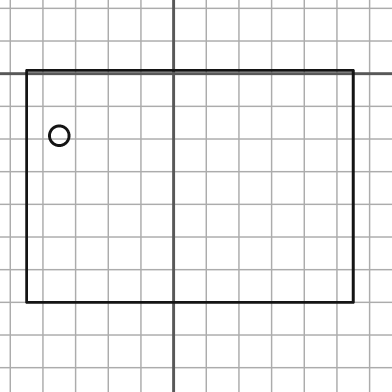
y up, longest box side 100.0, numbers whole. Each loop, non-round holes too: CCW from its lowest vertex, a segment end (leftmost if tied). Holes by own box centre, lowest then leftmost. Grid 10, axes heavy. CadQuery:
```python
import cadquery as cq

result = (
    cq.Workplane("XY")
    .moveTo(-45.0, -70.0)
    .lineTo(55.0, -70.0)
    .lineTo(55.0, 1.0)
    .lineTo(-45.0, 1.0)
    .close()
    .moveTo(-35.0, -19.0)
    .circle(3.0)
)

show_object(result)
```